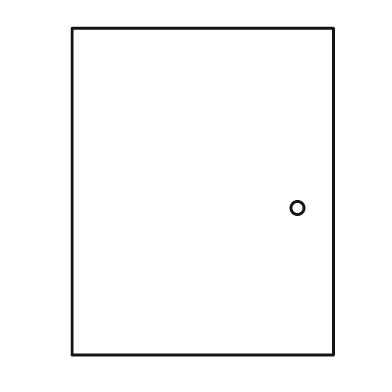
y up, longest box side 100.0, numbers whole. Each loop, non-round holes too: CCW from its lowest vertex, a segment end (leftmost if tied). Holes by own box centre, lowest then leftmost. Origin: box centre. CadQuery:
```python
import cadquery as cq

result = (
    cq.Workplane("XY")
    .moveTo(-40.0, -50.0)
    .lineTo(40.0, -50.0)
    .lineTo(40.0, 50.0)
    .lineTo(-40.0, 50.0)
    .close()
    .moveTo(29.0, -5.0)
    .circle(2.0)
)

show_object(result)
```